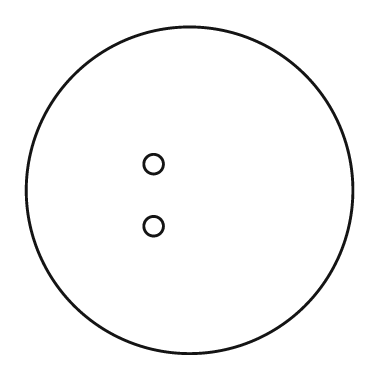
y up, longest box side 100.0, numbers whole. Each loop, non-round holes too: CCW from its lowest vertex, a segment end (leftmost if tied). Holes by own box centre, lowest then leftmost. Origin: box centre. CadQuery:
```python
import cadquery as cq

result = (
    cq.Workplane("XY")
    .moveTo(0.0, 0.0)
    .circle(50.0)
    .moveTo(-11.0, -11.0)
    .circle(3.0)
    .moveTo(-11.0, 8.0)
    .circle(3.0)
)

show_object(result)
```